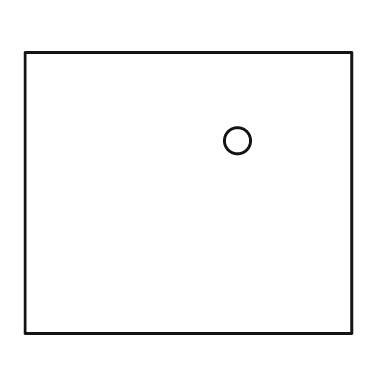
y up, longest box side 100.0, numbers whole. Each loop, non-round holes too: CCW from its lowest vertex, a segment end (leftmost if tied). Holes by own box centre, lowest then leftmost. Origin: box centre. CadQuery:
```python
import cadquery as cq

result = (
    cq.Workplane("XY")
    .moveTo(-50.0, -43.0)
    .lineTo(50.0, -43.0)
    .lineTo(50.0, 43.0)
    .lineTo(-50.0, 43.0)
    .close()
    .moveTo(15.0, 16.0)
    .circle(4.0)
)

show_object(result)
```